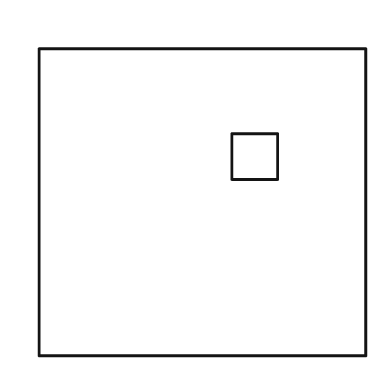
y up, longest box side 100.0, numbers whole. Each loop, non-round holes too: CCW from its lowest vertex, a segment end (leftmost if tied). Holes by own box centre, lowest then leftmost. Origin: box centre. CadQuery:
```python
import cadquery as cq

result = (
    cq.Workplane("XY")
    .moveTo(-50.0, -47.0)
    .lineTo(50.0, -47.0)
    .lineTo(50.0, 47.0)
    .lineTo(-50.0, 47.0)
    .close()
    .moveTo(9.0, 7.0)
    .lineTo(23.0, 7.0)
    .lineTo(23.0, 21.0)
    .lineTo(9.0, 21.0)
    .close()
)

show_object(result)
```